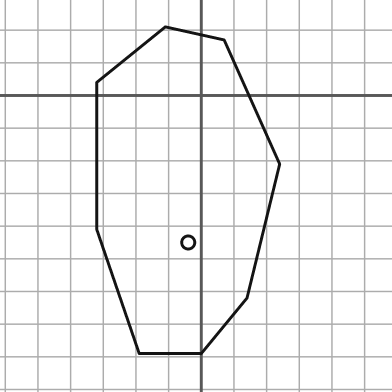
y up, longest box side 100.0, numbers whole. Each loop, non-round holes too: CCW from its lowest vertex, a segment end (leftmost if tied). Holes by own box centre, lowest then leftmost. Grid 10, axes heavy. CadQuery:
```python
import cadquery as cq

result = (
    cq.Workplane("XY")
    .moveTo(-19.0, -79.0)
    .lineTo(0.0, -79.0)
    .lineTo(14.0, -62.0)
    .lineTo(24.0, -21.0)
    .lineTo(7.0, 17.0)
    .lineTo(-11.0, 21.0)
    .lineTo(-32.0, 4.0)
    .lineTo(-32.0, -41.0)
    .close()
    .moveTo(-4.0, -45.0)
    .circle(2.0)
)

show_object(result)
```